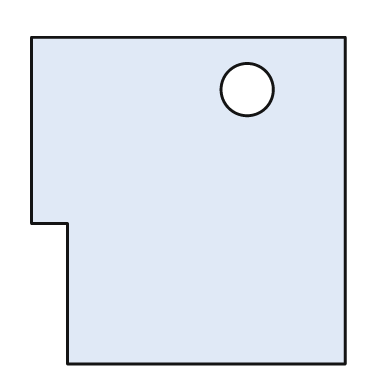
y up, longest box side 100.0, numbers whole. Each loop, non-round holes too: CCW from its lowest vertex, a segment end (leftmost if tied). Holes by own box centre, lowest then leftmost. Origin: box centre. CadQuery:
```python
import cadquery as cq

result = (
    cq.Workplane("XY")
    .moveTo(-37.0, -50.0)
    .lineTo(48.0, -50.0)
    .lineTo(48.0, 50.0)
    .lineTo(-48.0, 50.0)
    .lineTo(-48.0, -7.0)
    .lineTo(-37.0, -7.0)
    .close()
    .moveTo(18.0, 34.0)
    .circle(8.0)
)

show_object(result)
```